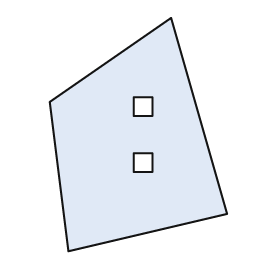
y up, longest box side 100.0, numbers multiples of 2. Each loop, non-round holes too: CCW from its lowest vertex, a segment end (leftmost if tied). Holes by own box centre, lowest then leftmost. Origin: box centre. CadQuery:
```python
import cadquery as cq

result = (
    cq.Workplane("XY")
    .moveTo(-30.0, -50.0)
    .lineTo(38.0, -34.0)
    .lineTo(14.0, 50.0)
    .lineTo(-38.0, 14.0)
    .close()
    .moveTo(-2.0, -16.0)
    .lineTo(6.0, -16.0)
    .lineTo(6.0, -8.0)
    .lineTo(-2.0, -8.0)
    .close()
    .moveTo(-2.0, 8.0)
    .lineTo(6.0, 8.0)
    .lineTo(6.0, 16.0)
    .lineTo(-2.0, 16.0)
    .close()
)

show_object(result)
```